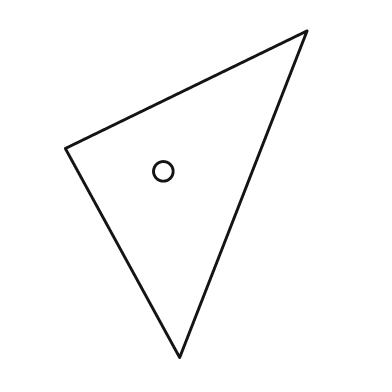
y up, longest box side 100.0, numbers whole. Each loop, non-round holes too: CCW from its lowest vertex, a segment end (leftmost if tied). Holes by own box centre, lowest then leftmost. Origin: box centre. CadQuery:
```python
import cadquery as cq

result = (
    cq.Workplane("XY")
    .moveTo(-2.0, -50.0)
    .lineTo(37.0, 50.0)
    .lineTo(-37.0, 14.0)
    .close()
    .moveTo(-7.0, 7.0)
    .circle(3.0)
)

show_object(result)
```